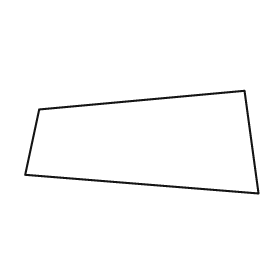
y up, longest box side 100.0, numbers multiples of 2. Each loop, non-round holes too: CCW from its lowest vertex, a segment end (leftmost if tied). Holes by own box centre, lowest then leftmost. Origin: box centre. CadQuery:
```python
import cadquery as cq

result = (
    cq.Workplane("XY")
    .moveTo(50.0, -22.0)
    .lineTo(44.0, 22.0)
    .lineTo(-44.0, 14.0)
    .lineTo(-50.0, -14.0)
    .close()
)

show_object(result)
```